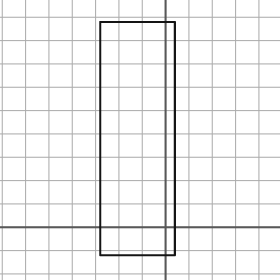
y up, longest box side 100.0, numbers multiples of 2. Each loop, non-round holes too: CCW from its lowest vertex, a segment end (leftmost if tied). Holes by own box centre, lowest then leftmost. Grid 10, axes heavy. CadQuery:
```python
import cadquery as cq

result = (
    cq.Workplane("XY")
    .moveTo(-28.0, -12.0)
    .lineTo(4.0, -12.0)
    .lineTo(4.0, 88.0)
    .lineTo(-28.0, 88.0)
    .close()
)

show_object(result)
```